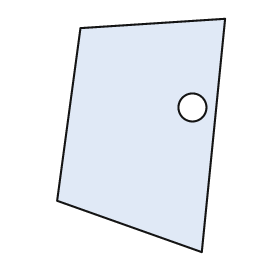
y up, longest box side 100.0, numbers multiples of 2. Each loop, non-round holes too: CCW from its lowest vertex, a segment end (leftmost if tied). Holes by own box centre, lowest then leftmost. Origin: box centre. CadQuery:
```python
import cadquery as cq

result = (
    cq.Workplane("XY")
    .moveTo(26.0, -50.0)
    .lineTo(36.0, 50.0)
    .lineTo(-26.0, 46.0)
    .lineTo(-36.0, -28.0)
    .close()
    .moveTo(22.0, 12.0)
    .circle(6.0)
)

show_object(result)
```